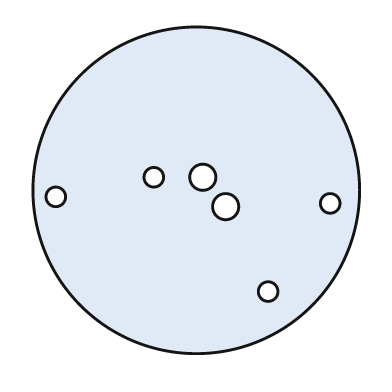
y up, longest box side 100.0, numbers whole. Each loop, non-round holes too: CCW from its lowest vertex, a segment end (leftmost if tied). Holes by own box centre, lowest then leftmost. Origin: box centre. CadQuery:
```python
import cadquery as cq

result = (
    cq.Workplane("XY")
    .moveTo(0.0, 0.0)
    .circle(50.0)
    .moveTo(22.0, -31.0)
    .circle(3.0)
    .moveTo(9.0, -5.0)
    .circle(4.0)
    .moveTo(41.0, -4.0)
    .circle(3.0)
    .moveTo(-43.0, -2.0)
    .circle(3.0)
    .moveTo(-13.0, 4.0)
    .circle(3.0)
    .moveTo(2.0, 4.0)
    .circle(4.0)
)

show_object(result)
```